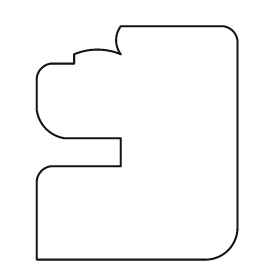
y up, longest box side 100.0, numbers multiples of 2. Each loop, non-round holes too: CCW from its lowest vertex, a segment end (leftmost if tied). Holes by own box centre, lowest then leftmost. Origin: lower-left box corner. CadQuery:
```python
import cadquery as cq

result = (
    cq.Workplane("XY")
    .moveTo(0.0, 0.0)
    .lineTo(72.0, 0.0)
    .threePointArc((82.0, 4.0), (86.0, 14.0))
    .lineTo(86.0, 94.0)
    .threePointArc((84.0, 98.0), (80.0, 100.0))
    .lineTo(36.0, 100.0)
    .threePointArc((34.0, 94.0), (36.0, 88.0))
    .threePointArc((26.0, 90.0), (16.0, 88.0))
    .lineTo(16.0, 84.0)
    .lineTo(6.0, 84.0)
    .threePointArc((2.0, 82.0), (0.0, 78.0))
    .lineTo(0.0, 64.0)
    .threePointArc((4.0, 56.0), (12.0, 52.0))
    .lineTo(36.0, 52.0)
    .lineTo(36.0, 40.0)
    .lineTo(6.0, 40.0)
    .threePointArc((2.0, 38.0), (0.0, 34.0))
    .close()
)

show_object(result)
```